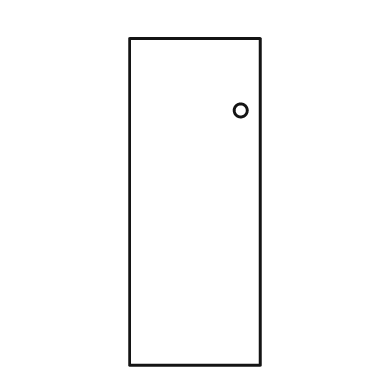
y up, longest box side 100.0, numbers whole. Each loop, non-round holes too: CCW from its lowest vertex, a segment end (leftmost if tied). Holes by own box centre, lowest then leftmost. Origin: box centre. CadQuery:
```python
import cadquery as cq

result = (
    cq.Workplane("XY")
    .moveTo(-20.0, -50.0)
    .lineTo(20.0, -50.0)
    .lineTo(20.0, 50.0)
    .lineTo(-20.0, 50.0)
    .close()
    .moveTo(14.0, 28.0)
    .circle(2.0)
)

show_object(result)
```